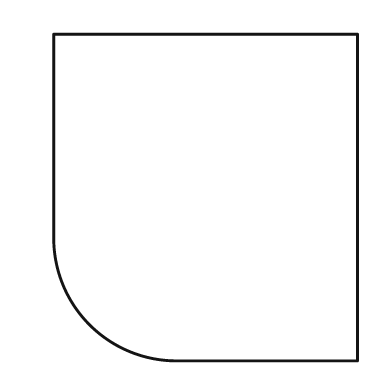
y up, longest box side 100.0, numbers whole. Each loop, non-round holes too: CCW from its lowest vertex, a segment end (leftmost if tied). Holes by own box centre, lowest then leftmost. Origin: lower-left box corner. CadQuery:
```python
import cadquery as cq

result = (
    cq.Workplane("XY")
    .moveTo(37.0, 0.0)
    .lineTo(93.0, 0.0)
    .lineTo(93.0, 100.0)
    .lineTo(0.0, 100.0)
    .lineTo(0.0, 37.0)
    .threePointArc((11.0, 11.0), (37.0, 0.0))
    .close()
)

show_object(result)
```